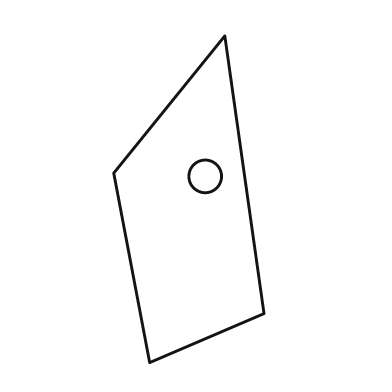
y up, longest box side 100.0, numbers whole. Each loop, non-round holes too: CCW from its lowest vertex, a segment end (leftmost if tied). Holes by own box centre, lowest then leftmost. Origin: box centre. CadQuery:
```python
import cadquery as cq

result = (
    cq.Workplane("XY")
    .moveTo(-12.0, -50.0)
    .lineTo(23.0, -35.0)
    .lineTo(11.0, 50.0)
    .lineTo(-23.0, 8.0)
    .close()
    .moveTo(5.0, 7.0)
    .circle(5.0)
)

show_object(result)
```